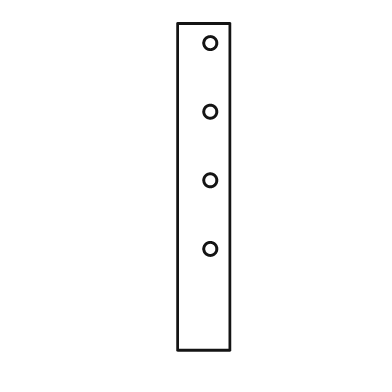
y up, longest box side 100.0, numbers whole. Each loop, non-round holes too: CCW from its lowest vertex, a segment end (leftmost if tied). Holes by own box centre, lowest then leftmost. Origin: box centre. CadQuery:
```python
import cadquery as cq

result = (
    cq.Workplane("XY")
    .moveTo(-8.0, -50.0)
    .lineTo(8.0, -50.0)
    .lineTo(8.0, 50.0)
    .lineTo(-8.0, 50.0)
    .close()
    .moveTo(2.0, -19.0)
    .circle(2.0)
    .moveTo(2.0, 2.0)
    .circle(2.0)
    .moveTo(2.0, 23.0)
    .circle(2.0)
    .moveTo(2.0, 44.0)
    .circle(2.0)
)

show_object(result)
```